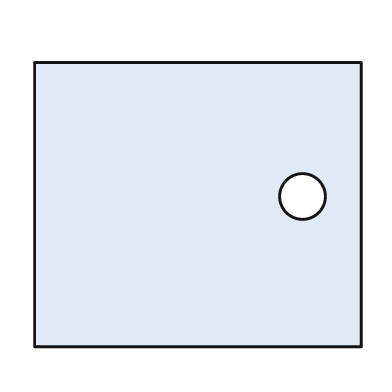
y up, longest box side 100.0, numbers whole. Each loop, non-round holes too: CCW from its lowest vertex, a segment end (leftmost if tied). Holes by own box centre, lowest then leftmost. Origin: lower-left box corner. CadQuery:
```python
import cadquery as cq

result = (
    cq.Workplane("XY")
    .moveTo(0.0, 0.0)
    .lineTo(100.0, 0.0)
    .lineTo(100.0, 87.0)
    .lineTo(0.0, 87.0)
    .close()
    .moveTo(82.0, 46.0)
    .circle(7.0)
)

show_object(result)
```